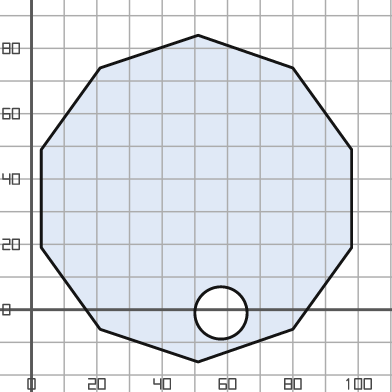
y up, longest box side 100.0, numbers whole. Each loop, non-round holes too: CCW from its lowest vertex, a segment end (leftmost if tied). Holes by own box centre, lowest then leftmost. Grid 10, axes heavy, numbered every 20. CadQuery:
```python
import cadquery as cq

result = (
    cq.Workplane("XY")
    .moveTo(51.0, -16.0)
    .lineTo(80.0, -6.0)
    .lineTo(98.0, 19.0)
    .lineTo(98.0, 49.0)
    .lineTo(80.0, 74.0)
    .lineTo(51.0, 84.0)
    .lineTo(21.0, 74.0)
    .lineTo(3.0, 49.0)
    .lineTo(3.0, 19.0)
    .lineTo(21.0, -6.0)
    .close()
    .moveTo(58.0, -1.0)
    .circle(8.0)
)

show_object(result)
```